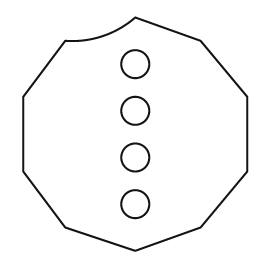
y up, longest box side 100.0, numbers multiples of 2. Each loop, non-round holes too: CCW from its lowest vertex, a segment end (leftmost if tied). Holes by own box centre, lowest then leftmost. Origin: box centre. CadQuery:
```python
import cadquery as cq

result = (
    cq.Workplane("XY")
    .moveTo(0.0, -50.0)
    .lineTo(28.0, -40.0)
    .lineTo(48.0, -16.0)
    .lineTo(48.0, 16.0)
    .lineTo(28.0, 40.0)
    .lineTo(0.0, 50.0)
    .threePointArc((-14.0, 42.0), (-30.0, 40.0))
    .lineTo(-48.0, 16.0)
    .lineTo(-48.0, -16.0)
    .lineTo(-30.0, -40.0)
    .close()
    .moveTo(0.0, -30.0)
    .circle(6.0)
    .moveTo(0.0, -10.0)
    .circle(6.0)
    .moveTo(0.0, 10.0)
    .circle(6.0)
    .moveTo(0.0, 30.0)
    .circle(6.0)
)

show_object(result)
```